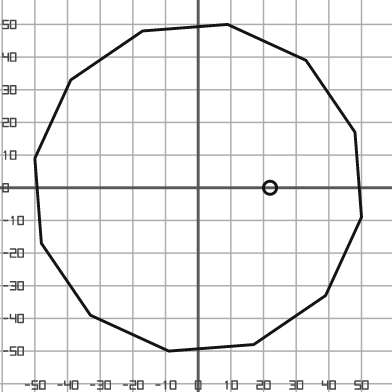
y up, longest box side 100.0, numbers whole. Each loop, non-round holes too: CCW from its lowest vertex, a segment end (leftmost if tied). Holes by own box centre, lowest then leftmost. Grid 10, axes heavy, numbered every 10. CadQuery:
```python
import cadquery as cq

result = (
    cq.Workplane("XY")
    .moveTo(-9.0, -50.0)
    .lineTo(17.0, -48.0)
    .lineTo(39.0, -33.0)
    .lineTo(50.0, -9.0)
    .lineTo(48.0, 17.0)
    .lineTo(33.0, 39.0)
    .lineTo(9.0, 50.0)
    .lineTo(-17.0, 48.0)
    .lineTo(-39.0, 33.0)
    .lineTo(-50.0, 9.0)
    .lineTo(-48.0, -17.0)
    .lineTo(-33.0, -39.0)
    .close()
    .moveTo(22.0, 0.0)
    .circle(2.0)
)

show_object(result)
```